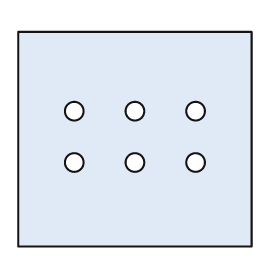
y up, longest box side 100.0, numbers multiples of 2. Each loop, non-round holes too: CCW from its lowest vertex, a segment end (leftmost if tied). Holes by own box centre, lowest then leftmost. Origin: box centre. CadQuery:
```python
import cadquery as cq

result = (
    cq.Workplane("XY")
    .moveTo(-50.0, -46.0)
    .lineTo(50.0, -46.0)
    .lineTo(50.0, 46.0)
    .lineTo(-50.0, 46.0)
    .close()
    .moveTo(-26.0, -10.0)
    .circle(4.0)
    .moveTo(0.0, -10.0)
    .circle(4.0)
    .moveTo(26.0, -10.0)
    .circle(4.0)
    .moveTo(-26.0, 12.0)
    .circle(4.0)
    .moveTo(0.0, 12.0)
    .circle(4.0)
    .moveTo(26.0, 12.0)
    .circle(4.0)
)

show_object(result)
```